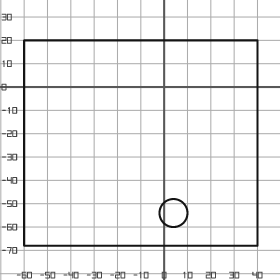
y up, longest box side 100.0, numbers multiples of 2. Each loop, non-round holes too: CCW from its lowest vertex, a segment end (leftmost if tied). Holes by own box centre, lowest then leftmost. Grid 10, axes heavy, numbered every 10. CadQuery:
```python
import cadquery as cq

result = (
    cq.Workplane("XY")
    .moveTo(-60.0, -68.0)
    .lineTo(40.0, -68.0)
    .lineTo(40.0, 20.0)
    .lineTo(-60.0, 20.0)
    .close()
    .moveTo(4.0, -54.0)
    .circle(6.0)
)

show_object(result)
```